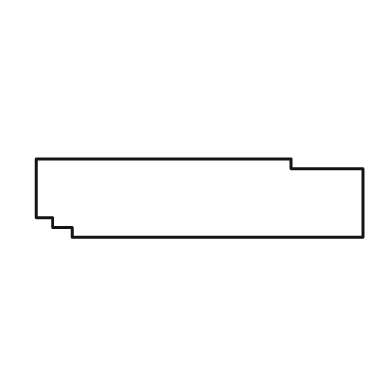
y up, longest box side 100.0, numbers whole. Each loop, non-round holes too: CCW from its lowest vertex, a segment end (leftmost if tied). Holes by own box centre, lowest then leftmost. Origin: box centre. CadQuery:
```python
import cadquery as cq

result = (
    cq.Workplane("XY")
    .moveTo(-39.0, -12.0)
    .lineTo(50.0, -12.0)
    .lineTo(50.0, 9.0)
    .lineTo(28.0, 9.0)
    .lineTo(28.0, 12.0)
    .lineTo(-50.0, 12.0)
    .lineTo(-50.0, -6.0)
    .lineTo(-45.0, -6.0)
    .lineTo(-45.0, -9.0)
    .lineTo(-39.0, -9.0)
    .close()
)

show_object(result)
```